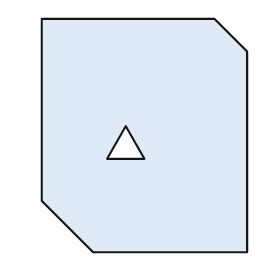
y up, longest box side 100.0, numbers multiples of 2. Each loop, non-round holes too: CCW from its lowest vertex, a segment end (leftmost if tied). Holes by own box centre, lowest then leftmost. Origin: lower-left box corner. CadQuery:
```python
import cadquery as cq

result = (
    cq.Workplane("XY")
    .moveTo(22.0, 0.0)
    .lineTo(88.0, 0.0)
    .lineTo(88.0, 86.0)
    .lineTo(74.0, 100.0)
    .lineTo(0.0, 100.0)
    .lineTo(0.0, 22.0)
    .close()
    .moveTo(28.0, 40.0)
    .lineTo(44.0, 40.0)
    .lineTo(36.0, 54.0)
    .close()
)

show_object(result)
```